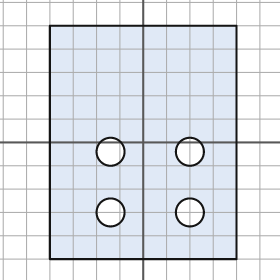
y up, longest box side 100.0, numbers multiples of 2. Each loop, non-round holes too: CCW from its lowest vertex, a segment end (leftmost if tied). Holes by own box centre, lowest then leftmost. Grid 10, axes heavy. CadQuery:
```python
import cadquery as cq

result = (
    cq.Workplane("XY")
    .moveTo(-40.0, -50.0)
    .lineTo(40.0, -50.0)
    .lineTo(40.0, 50.0)
    .lineTo(-40.0, 50.0)
    .close()
    .moveTo(-14.0, -30.0)
    .circle(6.0)
    .moveTo(20.0, -30.0)
    .circle(6.0)
    .moveTo(-14.0, -4.0)
    .circle(6.0)
    .moveTo(20.0, -4.0)
    .circle(6.0)
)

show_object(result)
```